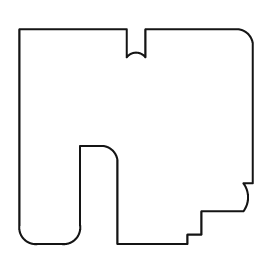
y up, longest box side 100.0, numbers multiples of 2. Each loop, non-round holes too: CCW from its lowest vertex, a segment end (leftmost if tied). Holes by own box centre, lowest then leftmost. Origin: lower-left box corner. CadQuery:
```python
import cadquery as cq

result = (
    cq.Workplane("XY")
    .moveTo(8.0, 0.0)
    .lineTo(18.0, 0.0)
    .threePointArc((24.0, 2.0), (26.0, 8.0))
    .lineTo(26.0, 42.0)
    .lineTo(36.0, 42.0)
    .threePointArc((40.0, 40.0), (42.0, 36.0))
    .lineTo(42.0, 0.0)
    .lineTo(72.0, 0.0)
    .lineTo(72.0, 4.0)
    .lineTo(78.0, 4.0)
    .lineTo(78.0, 14.0)
    .lineTo(96.0, 14.0)
    .threePointArc((98.0, 20.0), (96.0, 26.0))
    .lineTo(100.0, 26.0)
    .lineTo(100.0, 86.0)
    .threePointArc((98.0, 90.0), (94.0, 92.0))
    .lineTo(54.0, 92.0)
    .lineTo(54.0, 80.0)
    .threePointArc((50.0, 82.0), (46.0, 80.0))
    .lineTo(46.0, 92.0)
    .lineTo(0.0, 92.0)
    .lineTo(0.0, 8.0)
    .threePointArc((2.0, 2.0), (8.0, 0.0))
    .close()
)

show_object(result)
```